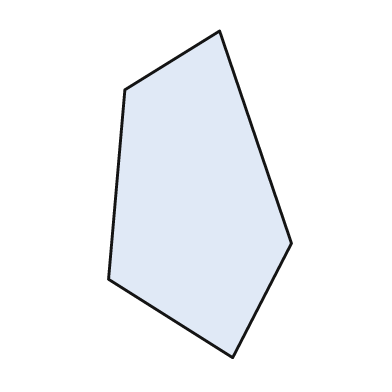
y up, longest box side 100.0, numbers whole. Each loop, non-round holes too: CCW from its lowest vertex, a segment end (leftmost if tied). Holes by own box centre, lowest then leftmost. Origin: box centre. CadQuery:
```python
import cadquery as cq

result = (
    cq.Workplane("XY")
    .moveTo(10.0, -50.0)
    .lineTo(28.0, -15.0)
    .lineTo(6.0, 50.0)
    .lineTo(-23.0, 32.0)
    .lineTo(-28.0, -26.0)
    .close()
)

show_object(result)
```